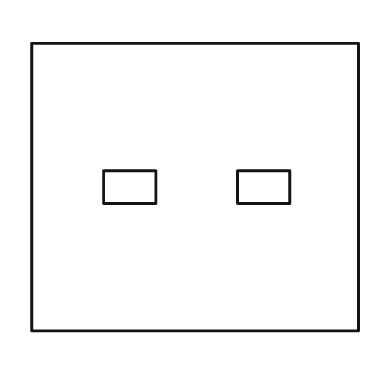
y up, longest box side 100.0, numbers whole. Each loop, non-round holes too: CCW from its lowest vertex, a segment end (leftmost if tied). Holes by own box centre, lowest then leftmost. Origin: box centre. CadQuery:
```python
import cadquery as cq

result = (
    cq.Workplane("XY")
    .moveTo(-50.0, -44.0)
    .lineTo(50.0, -44.0)
    .lineTo(50.0, 44.0)
    .lineTo(-50.0, 44.0)
    .close()
    .moveTo(-28.0, -5.0)
    .lineTo(-12.0, -5.0)
    .lineTo(-12.0, 5.0)
    .lineTo(-28.0, 5.0)
    .close()
    .moveTo(13.0, -5.0)
    .lineTo(29.0, -5.0)
    .lineTo(29.0, 5.0)
    .lineTo(13.0, 5.0)
    .close()
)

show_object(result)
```